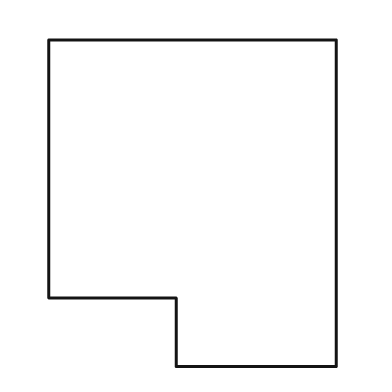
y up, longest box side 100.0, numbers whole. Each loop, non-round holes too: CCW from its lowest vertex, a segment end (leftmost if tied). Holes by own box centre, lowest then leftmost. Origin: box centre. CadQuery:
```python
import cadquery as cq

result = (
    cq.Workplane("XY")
    .moveTo(-5.0, -50.0)
    .lineTo(44.0, -50.0)
    .lineTo(44.0, 50.0)
    .lineTo(-44.0, 50.0)
    .lineTo(-44.0, -29.0)
    .lineTo(-5.0, -29.0)
    .close()
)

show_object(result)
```